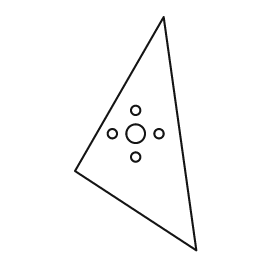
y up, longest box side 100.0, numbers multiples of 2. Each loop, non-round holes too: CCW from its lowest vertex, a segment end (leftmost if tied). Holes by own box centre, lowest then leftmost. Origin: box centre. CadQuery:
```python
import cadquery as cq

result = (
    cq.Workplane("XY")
    .moveTo(26.0, -50.0)
    .lineTo(12.0, 50.0)
    .lineTo(-26.0, -16.0)
    .close()
    .moveTo(0.0, -10.0)
    .circle(2.0)
    .moveTo(-10.0, 0.0)
    .circle(2.0)
    .moveTo(0.0, 0.0)
    .circle(4.0)
    .moveTo(10.0, 0.0)
    .circle(2.0)
    .moveTo(0.0, 10.0)
    .circle(2.0)
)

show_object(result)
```